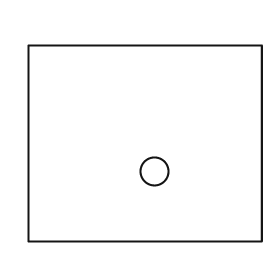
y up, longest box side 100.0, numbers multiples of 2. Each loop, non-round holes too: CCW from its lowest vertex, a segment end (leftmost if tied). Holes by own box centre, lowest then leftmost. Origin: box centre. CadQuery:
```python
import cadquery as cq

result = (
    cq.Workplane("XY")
    .moveTo(-50.0, -42.0)
    .lineTo(50.0, -42.0)
    .lineTo(50.0, 42.0)
    .lineTo(-50.0, 42.0)
    .close()
    .moveTo(4.0, -12.0)
    .circle(6.0)
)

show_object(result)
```